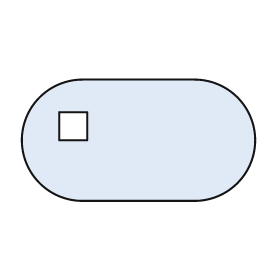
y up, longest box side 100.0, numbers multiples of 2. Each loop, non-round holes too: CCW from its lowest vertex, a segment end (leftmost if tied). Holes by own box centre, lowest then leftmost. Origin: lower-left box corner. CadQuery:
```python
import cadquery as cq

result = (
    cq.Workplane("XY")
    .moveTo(26.0, 0.0)
    .lineTo(74.0, 0.0)
    .threePointArc((100.0, 26.0), (74.0, 52.0))
    .lineTo(26.0, 52.0)
    .threePointArc((0.0, 26.0), (26.0, 0.0))
    .close()
    .moveTo(16.0, 26.0)
    .lineTo(28.0, 26.0)
    .lineTo(28.0, 38.0)
    .lineTo(16.0, 38.0)
    .close()
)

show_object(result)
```